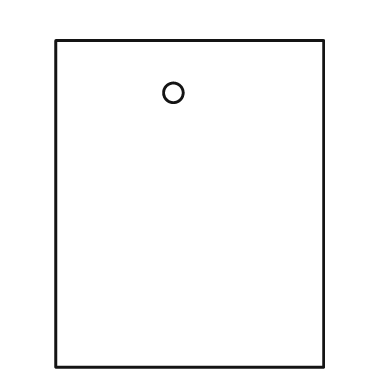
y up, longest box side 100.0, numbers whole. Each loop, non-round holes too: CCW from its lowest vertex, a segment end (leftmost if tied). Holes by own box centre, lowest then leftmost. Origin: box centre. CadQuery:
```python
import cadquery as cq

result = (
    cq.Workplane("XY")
    .moveTo(-41.0, -50.0)
    .lineTo(41.0, -50.0)
    .lineTo(41.0, 50.0)
    .lineTo(-41.0, 50.0)
    .close()
    .moveTo(-5.0, 34.0)
    .circle(3.0)
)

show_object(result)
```